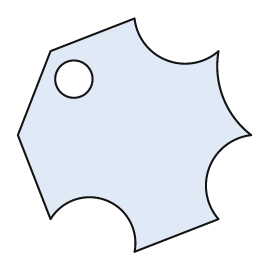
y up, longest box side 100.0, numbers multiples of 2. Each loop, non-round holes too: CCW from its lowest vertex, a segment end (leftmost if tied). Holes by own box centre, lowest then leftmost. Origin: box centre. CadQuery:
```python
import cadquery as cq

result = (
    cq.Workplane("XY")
    .moveTo(0.0, -50.0)
    .lineTo(36.0, -36.0)
    .threePointArc((32.0, -14.0), (50.0, 0.0))
    .threePointArc((38.0, 16.0), (36.0, 36.0))
    .threePointArc((14.0, 32.0), (0.0, 50.0))
    .lineTo(-36.0, 36.0)
    .lineTo(-50.0, 0.0)
    .lineTo(-36.0, -36.0)
    .threePointArc((-12.0, -28.0), (0.0, -50.0))
    .close()
    .moveTo(-26.0, 24.0)
    .circle(8.0)
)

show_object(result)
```